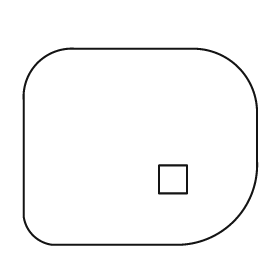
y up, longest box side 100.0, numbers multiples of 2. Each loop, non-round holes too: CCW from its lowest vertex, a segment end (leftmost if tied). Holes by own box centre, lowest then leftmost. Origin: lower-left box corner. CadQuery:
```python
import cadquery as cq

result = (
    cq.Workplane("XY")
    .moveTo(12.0, 0.0)
    .lineTo(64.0, 0.0)
    .threePointArc((90.0, 10.0), (100.0, 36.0))
    .lineTo(100.0, 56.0)
    .threePointArc((92.0, 76.0), (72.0, 84.0))
    .lineTo(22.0, 84.0)
    .threePointArc((6.0, 78.0), (0.0, 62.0))
    .lineTo(0.0, 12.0)
    .threePointArc((4.0, 4.0), (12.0, 0.0))
    .close()
    .moveTo(58.0, 22.0)
    .lineTo(70.0, 22.0)
    .lineTo(70.0, 34.0)
    .lineTo(58.0, 34.0)
    .close()
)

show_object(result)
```